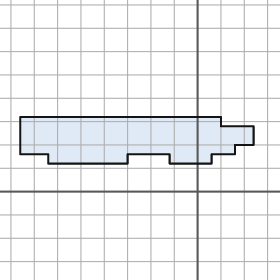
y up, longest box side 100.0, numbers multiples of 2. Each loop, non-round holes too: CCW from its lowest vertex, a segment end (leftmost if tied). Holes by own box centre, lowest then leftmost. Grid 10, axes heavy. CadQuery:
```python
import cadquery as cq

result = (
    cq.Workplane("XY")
    .moveTo(-64.0, 12.0)
    .lineTo(-30.0, 12.0)
    .lineTo(-30.0, 16.0)
    .lineTo(-12.0, 16.0)
    .lineTo(-12.0, 12.0)
    .lineTo(6.0, 12.0)
    .lineTo(6.0, 16.0)
    .lineTo(16.0, 16.0)
    .lineTo(16.0, 20.0)
    .lineTo(24.0, 20.0)
    .lineTo(24.0, 28.0)
    .lineTo(10.0, 28.0)
    .lineTo(10.0, 32.0)
    .lineTo(-76.0, 32.0)
    .lineTo(-76.0, 16.0)
    .lineTo(-64.0, 16.0)
    .close()
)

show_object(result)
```